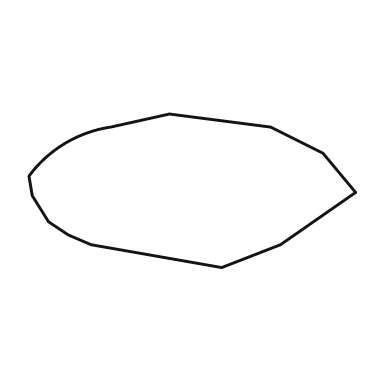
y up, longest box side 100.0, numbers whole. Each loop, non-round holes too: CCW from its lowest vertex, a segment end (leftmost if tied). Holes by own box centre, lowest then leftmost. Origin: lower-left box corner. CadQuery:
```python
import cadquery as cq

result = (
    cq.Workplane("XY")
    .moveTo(59.0, 0.0)
    .lineTo(77.0, 7.0)
    .lineTo(100.0, 23.0)
    .lineTo(90.0, 35.0)
    .lineTo(74.0, 43.0)
    .lineTo(43.0, 47.0)
    .lineTo(25.0, 43.0)
    .threePointArc((11.0, 38.0), (0.0, 28.0))
    .lineTo(1.0, 22.0)
    .lineTo(6.0, 14.0)
    .lineTo(12.0, 10.0)
    .lineTo(19.0, 7.0)
    .close()
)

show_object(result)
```